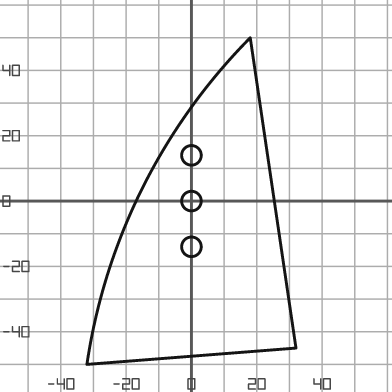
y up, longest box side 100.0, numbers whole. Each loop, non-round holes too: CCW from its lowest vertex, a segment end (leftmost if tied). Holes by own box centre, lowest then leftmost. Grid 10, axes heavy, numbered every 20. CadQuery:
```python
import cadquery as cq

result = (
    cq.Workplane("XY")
    .moveTo(-32.0, -50.0)
    .lineTo(32.0, -45.0)
    .lineTo(18.0, 50.0)
    .threePointArc((-15.0, 4.0), (-32.0, -50.0))
    .close()
    .moveTo(0.0, -14.0)
    .circle(3.0)
    .moveTo(0.0, 0.0)
    .circle(3.0)
    .moveTo(0.0, 14.0)
    .circle(3.0)
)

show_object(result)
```